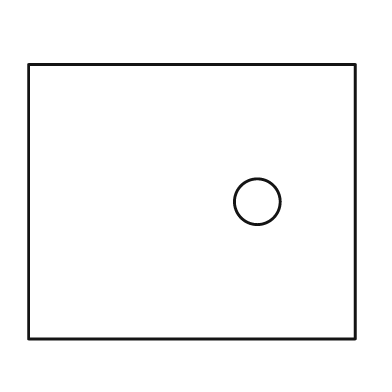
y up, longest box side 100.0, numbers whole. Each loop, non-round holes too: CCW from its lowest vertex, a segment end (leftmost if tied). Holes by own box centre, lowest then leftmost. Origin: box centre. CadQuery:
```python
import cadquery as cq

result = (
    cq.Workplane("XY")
    .moveTo(-50.0, -42.0)
    .lineTo(50.0, -42.0)
    .lineTo(50.0, 42.0)
    .lineTo(-50.0, 42.0)
    .close()
    .moveTo(20.0, 0.0)
    .circle(7.0)
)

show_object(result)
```